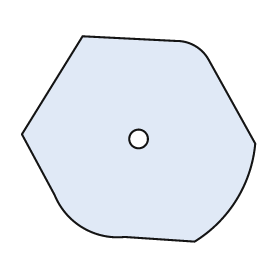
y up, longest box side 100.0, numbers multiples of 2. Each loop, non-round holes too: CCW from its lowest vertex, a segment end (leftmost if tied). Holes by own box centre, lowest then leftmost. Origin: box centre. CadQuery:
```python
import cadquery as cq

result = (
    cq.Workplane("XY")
    .moveTo(24.0, -44.0)
    .threePointArc((42.0, -26.0), (50.0, -2.0))
    .lineTo(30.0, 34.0)
    .threePointArc((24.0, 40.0), (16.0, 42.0))
    .lineTo(-24.0, 44.0)
    .lineTo(-50.0, 2.0)
    .lineTo(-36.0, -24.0)
    .threePointArc((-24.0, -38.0), (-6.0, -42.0))
    .close()
    .moveTo(0.0, 0.0)
    .circle(4.0)
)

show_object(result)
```